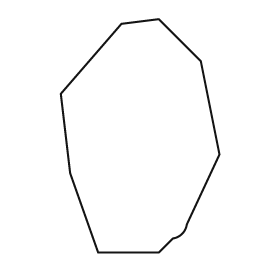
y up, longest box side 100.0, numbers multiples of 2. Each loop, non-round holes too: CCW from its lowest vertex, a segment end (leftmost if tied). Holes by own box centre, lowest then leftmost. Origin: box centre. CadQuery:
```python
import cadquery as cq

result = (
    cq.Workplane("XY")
    .moveTo(-18.0, -50.0)
    .lineTo(8.0, -50.0)
    .lineTo(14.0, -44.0)
    .threePointArc((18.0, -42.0), (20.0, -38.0))
    .lineTo(34.0, -8.0)
    .lineTo(26.0, 32.0)
    .lineTo(8.0, 50.0)
    .lineTo(-8.0, 48.0)
    .lineTo(-34.0, 18.0)
    .lineTo(-30.0, -16.0)
    .close()
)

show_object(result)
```